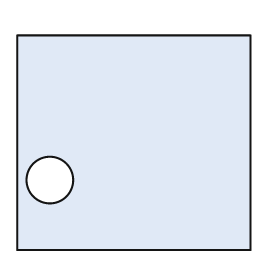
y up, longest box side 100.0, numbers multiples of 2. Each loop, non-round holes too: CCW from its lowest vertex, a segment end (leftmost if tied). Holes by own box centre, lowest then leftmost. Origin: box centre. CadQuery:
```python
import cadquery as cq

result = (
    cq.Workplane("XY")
    .moveTo(-50.0, -46.0)
    .lineTo(50.0, -46.0)
    .lineTo(50.0, 46.0)
    .lineTo(-50.0, 46.0)
    .close()
    .moveTo(-36.0, -16.0)
    .circle(10.0)
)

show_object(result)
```